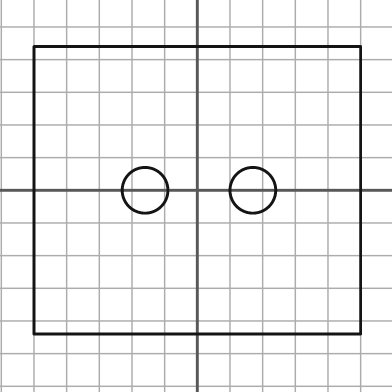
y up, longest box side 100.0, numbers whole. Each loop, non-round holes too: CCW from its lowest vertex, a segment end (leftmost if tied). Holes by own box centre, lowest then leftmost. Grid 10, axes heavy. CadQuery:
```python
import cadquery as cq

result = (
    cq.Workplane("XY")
    .moveTo(-50.0, -44.0)
    .lineTo(50.0, -44.0)
    .lineTo(50.0, 44.0)
    .lineTo(-50.0, 44.0)
    .close()
    .moveTo(-16.0, 0.0)
    .circle(7.0)
    .moveTo(17.0, 0.0)
    .circle(7.0)
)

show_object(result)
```